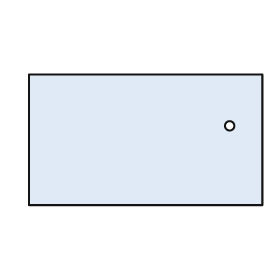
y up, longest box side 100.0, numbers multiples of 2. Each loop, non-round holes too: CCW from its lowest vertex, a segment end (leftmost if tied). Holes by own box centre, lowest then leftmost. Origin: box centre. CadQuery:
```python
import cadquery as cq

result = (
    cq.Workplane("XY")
    .moveTo(-50.0, -28.0)
    .lineTo(50.0, -28.0)
    .lineTo(50.0, 28.0)
    .lineTo(-50.0, 28.0)
    .close()
    .moveTo(36.0, 6.0)
    .circle(2.0)
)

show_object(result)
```